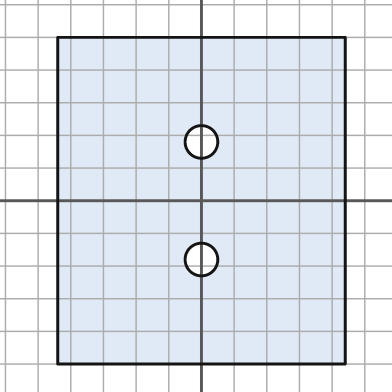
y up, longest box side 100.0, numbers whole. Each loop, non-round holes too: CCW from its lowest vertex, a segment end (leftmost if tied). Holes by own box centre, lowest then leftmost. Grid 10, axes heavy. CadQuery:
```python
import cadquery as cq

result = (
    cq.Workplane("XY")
    .moveTo(-44.0, -50.0)
    .lineTo(44.0, -50.0)
    .lineTo(44.0, 50.0)
    .lineTo(-44.0, 50.0)
    .close()
    .moveTo(0.0, -18.0)
    .circle(5.0)
    .moveTo(0.0, 18.0)
    .circle(5.0)
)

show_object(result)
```